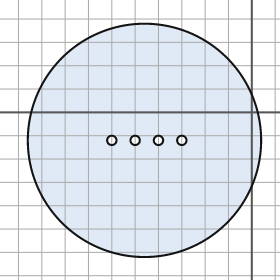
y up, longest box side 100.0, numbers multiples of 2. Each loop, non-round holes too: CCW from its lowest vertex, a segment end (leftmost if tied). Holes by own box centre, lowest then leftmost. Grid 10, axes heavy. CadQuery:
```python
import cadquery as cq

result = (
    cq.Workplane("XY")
    .moveTo(-46.0, -12.0)
    .circle(50.0)
    .moveTo(-60.0, -12.0)
    .circle(2.0)
    .moveTo(-50.0, -12.0)
    .circle(2.0)
    .moveTo(-40.0, -12.0)
    .circle(2.0)
    .moveTo(-30.0, -12.0)
    .circle(2.0)
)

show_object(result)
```